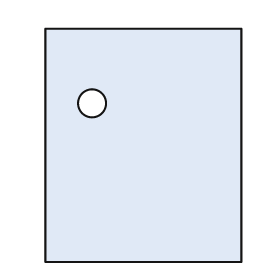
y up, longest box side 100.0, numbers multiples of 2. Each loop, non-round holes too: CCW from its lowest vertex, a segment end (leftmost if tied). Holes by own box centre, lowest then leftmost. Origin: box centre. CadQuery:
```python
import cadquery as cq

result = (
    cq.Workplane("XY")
    .moveTo(-42.0, -50.0)
    .lineTo(42.0, -50.0)
    .lineTo(42.0, 50.0)
    .lineTo(-42.0, 50.0)
    .close()
    .moveTo(-22.0, 18.0)
    .circle(6.0)
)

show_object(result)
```